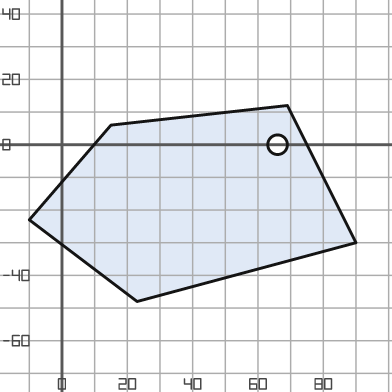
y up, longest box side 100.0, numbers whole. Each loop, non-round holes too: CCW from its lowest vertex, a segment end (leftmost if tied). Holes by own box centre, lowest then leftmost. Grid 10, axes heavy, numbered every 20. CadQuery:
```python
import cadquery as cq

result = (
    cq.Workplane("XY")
    .moveTo(23.0, -48.0)
    .lineTo(90.0, -30.0)
    .lineTo(69.0, 12.0)
    .lineTo(15.0, 6.0)
    .lineTo(-10.0, -23.0)
    .close()
    .moveTo(66.0, 0.0)
    .circle(3.0)
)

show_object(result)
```